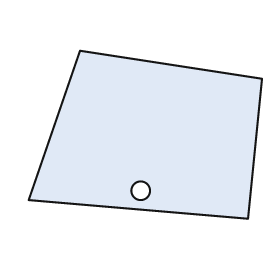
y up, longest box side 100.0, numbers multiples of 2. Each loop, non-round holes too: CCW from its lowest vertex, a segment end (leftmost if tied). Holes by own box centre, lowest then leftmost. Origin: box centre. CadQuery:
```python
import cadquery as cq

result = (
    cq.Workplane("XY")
    .moveTo(44.0, -36.0)
    .lineTo(50.0, 24.0)
    .lineTo(-28.0, 36.0)
    .lineTo(-50.0, -28.0)
    .close()
    .moveTo(-2.0, -24.0)
    .circle(4.0)
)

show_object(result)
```